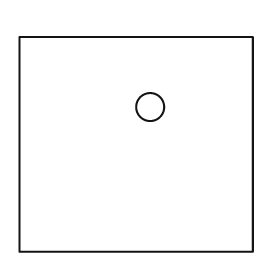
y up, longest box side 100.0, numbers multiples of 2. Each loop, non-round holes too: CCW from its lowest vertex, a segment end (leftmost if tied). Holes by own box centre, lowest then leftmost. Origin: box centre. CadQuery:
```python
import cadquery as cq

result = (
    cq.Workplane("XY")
    .moveTo(-50.0, -46.0)
    .lineTo(50.0, -46.0)
    .lineTo(50.0, 46.0)
    .lineTo(-50.0, 46.0)
    .close()
    .moveTo(6.0, 16.0)
    .circle(6.0)
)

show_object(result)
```